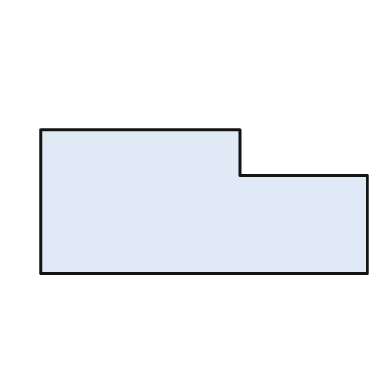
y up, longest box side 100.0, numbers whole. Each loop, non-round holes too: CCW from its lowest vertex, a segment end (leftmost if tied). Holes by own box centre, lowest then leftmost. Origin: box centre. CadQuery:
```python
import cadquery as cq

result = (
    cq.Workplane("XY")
    .moveTo(-50.0, -22.0)
    .lineTo(50.0, -22.0)
    .lineTo(50.0, 8.0)
    .lineTo(11.0, 8.0)
    .lineTo(11.0, 22.0)
    .lineTo(-50.0, 22.0)
    .close()
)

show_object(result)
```